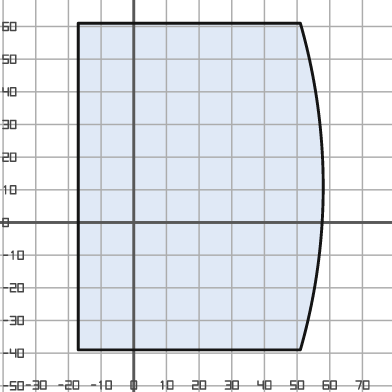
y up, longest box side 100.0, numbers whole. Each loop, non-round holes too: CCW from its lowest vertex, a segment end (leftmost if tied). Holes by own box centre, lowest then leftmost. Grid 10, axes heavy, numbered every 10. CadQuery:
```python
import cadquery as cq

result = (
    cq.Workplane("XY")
    .moveTo(-17.0, -39.0)
    .lineTo(51.0, -39.0)
    .threePointArc((58.0, 11.0), (51.0, 61.0))
    .lineTo(-17.0, 61.0)
    .close()
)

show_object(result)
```